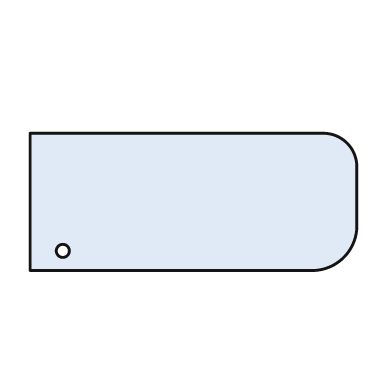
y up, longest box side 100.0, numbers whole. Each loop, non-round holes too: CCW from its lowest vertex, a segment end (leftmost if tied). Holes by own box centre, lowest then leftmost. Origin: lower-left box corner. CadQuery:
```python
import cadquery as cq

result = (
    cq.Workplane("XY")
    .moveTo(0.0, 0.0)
    .lineTo(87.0, 0.0)
    .threePointArc((96.0, 4.0), (100.0, 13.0))
    .lineTo(100.0, 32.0)
    .threePointArc((97.0, 39.0), (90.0, 42.0))
    .lineTo(0.0, 42.0)
    .close()
    .moveTo(10.0, 6.0)
    .circle(2.0)
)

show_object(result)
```